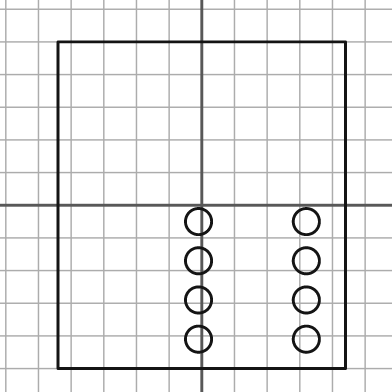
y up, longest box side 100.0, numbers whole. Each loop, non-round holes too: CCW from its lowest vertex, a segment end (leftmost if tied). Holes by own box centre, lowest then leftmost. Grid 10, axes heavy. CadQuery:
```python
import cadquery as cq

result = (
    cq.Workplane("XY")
    .moveTo(-44.0, -50.0)
    .lineTo(44.0, -50.0)
    .lineTo(44.0, 50.0)
    .lineTo(-44.0, 50.0)
    .close()
    .moveTo(-1.0, -41.0)
    .circle(4.0)
    .moveTo(32.0, -41.0)
    .circle(4.0)
    .moveTo(-1.0, -29.0)
    .circle(4.0)
    .moveTo(32.0, -29.0)
    .circle(4.0)
    .moveTo(-1.0, -17.0)
    .circle(4.0)
    .moveTo(32.0, -17.0)
    .circle(4.0)
    .moveTo(-1.0, -5.0)
    .circle(4.0)
    .moveTo(32.0, -5.0)
    .circle(4.0)
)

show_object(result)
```